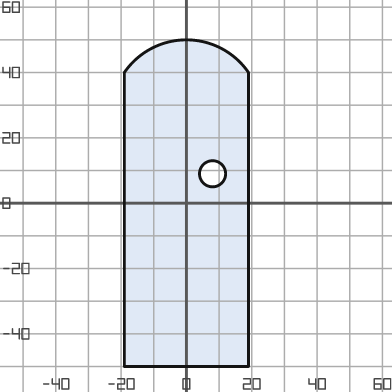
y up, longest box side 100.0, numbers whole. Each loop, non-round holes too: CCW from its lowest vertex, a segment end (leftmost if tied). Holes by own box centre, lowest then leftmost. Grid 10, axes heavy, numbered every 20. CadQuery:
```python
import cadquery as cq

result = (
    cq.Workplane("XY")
    .moveTo(-19.0, -50.0)
    .lineTo(19.0, -50.0)
    .lineTo(19.0, 40.0)
    .threePointArc((0.0, 50.0), (-19.0, 40.0))
    .close()
    .moveTo(8.0, 9.0)
    .circle(4.0)
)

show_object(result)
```